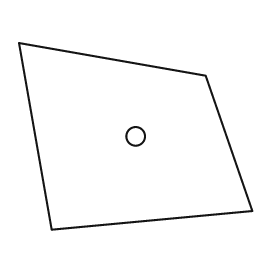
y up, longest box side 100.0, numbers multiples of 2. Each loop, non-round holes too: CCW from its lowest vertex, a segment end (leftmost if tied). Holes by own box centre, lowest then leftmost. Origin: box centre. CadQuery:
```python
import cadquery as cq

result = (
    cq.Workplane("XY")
    .moveTo(-36.0, -40.0)
    .lineTo(50.0, -32.0)
    .lineTo(30.0, 26.0)
    .lineTo(-50.0, 40.0)
    .close()
    .moveTo(0.0, 0.0)
    .circle(4.0)
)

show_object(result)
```